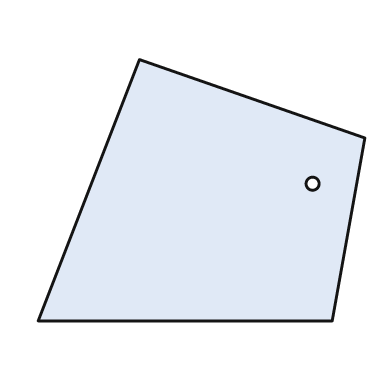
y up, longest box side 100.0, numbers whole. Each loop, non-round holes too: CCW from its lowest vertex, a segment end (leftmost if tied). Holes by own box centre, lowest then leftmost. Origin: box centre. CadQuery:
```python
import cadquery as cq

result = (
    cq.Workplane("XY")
    .moveTo(-50.0, -40.0)
    .lineTo(40.0, -40.0)
    .lineTo(50.0, 16.0)
    .lineTo(-19.0, 40.0)
    .close()
    .moveTo(34.0, 2.0)
    .circle(2.0)
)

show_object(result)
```